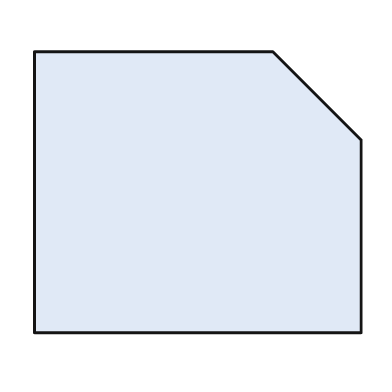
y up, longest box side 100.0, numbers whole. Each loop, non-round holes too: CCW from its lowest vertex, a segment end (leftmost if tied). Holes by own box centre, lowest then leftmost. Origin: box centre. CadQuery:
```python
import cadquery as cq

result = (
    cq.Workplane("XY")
    .moveTo(-50.0, -43.0)
    .lineTo(50.0, -43.0)
    .lineTo(50.0, 16.0)
    .lineTo(23.0, 43.0)
    .lineTo(-50.0, 43.0)
    .close()
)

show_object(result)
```